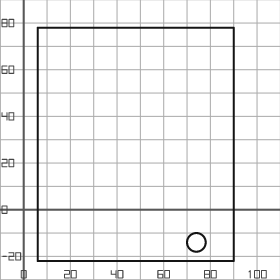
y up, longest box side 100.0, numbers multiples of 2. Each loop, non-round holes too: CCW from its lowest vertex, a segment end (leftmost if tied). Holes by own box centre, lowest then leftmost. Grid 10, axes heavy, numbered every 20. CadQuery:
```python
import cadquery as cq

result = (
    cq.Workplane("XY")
    .moveTo(6.0, -22.0)
    .lineTo(90.0, -22.0)
    .lineTo(90.0, 78.0)
    .lineTo(6.0, 78.0)
    .close()
    .moveTo(74.0, -14.0)
    .circle(4.0)
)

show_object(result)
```